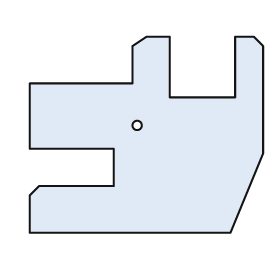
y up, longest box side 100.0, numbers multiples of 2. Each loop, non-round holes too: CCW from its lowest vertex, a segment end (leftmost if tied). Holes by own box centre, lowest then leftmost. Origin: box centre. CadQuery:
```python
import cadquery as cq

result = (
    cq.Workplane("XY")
    .moveTo(-50.0, -42.0)
    .lineTo(36.0, -42.0)
    .lineTo(50.0, -8.0)
    .lineTo(50.0, 38.0)
    .lineTo(46.0, 42.0)
    .lineTo(38.0, 42.0)
    .lineTo(38.0, 16.0)
    .lineTo(10.0, 16.0)
    .lineTo(10.0, 42.0)
    .lineTo(0.0, 42.0)
    .lineTo(-6.0, 38.0)
    .lineTo(-6.0, 22.0)
    .lineTo(-50.0, 22.0)
    .lineTo(-50.0, -6.0)
    .lineTo(-14.0, -6.0)
    .lineTo(-14.0, -22.0)
    .lineTo(-46.0, -22.0)
    .lineTo(-50.0, -26.0)
    .close()
    .moveTo(-4.0, 4.0)
    .circle(2.0)
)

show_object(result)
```